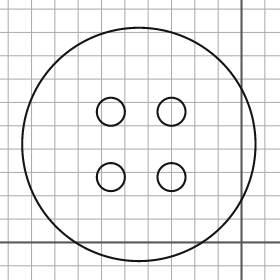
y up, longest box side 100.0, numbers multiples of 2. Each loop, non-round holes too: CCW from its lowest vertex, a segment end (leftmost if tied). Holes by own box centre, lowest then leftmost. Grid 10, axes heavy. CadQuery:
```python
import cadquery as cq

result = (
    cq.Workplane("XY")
    .moveTo(-44.0, 42.0)
    .circle(50.0)
    .moveTo(-56.0, 28.0)
    .circle(6.0)
    .moveTo(-30.0, 28.0)
    .circle(6.0)
    .moveTo(-56.0, 56.0)
    .circle(6.0)
    .moveTo(-30.0, 56.0)
    .circle(6.0)
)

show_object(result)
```